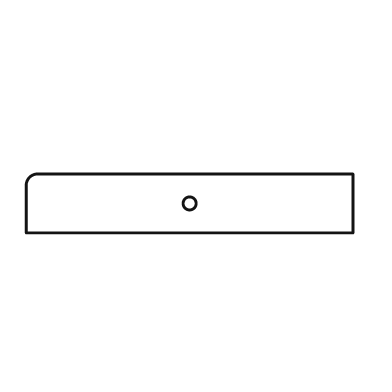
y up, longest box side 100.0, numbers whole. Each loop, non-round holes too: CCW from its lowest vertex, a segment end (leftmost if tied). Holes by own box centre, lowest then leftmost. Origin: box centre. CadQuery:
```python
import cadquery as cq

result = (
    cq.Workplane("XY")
    .moveTo(-50.0, -9.0)
    .lineTo(50.0, -9.0)
    .lineTo(50.0, 9.0)
    .lineTo(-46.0, 9.0)
    .threePointArc((-49.0, 8.0), (-50.0, 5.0))
    .close()
    .moveTo(0.0, 0.0)
    .circle(2.0)
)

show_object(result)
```